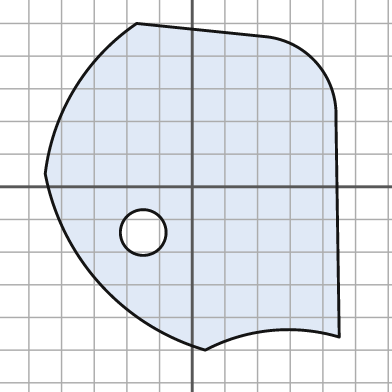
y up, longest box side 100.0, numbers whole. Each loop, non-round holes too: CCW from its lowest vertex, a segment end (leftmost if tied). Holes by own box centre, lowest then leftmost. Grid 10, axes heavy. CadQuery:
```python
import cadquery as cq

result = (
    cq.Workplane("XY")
    .moveTo(4.0, -50.0)
    .threePointArc((24.0, -44.0), (45.0, -46.0))
    .lineTo(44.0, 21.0)
    .threePointArc((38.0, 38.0), (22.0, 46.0))
    .lineTo(-17.0, 50.0)
    .threePointArc((-36.0, 30.0), (-45.0, 4.0))
    .threePointArc((-28.0, -30.0), (4.0, -50.0))
    .close()
    .moveTo(-15.0, -14.0)
    .circle(7.0)
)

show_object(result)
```